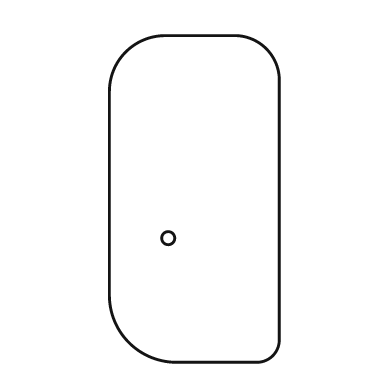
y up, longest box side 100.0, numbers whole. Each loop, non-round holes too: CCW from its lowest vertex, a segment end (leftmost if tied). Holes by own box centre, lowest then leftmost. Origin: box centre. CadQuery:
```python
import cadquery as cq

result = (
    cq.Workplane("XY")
    .moveTo(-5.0, -50.0)
    .lineTo(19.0, -50.0)
    .threePointArc((24.0, -48.0), (26.0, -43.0))
    .lineTo(26.0, 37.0)
    .threePointArc((22.0, 46.0), (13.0, 50.0))
    .lineTo(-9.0, 50.0)
    .threePointArc((-21.0, 45.0), (-26.0, 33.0))
    .lineTo(-26.0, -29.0)
    .threePointArc((-20.0, -44.0), (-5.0, -50.0))
    .close()
    .moveTo(-8.0, -12.0)
    .circle(2.0)
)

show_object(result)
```